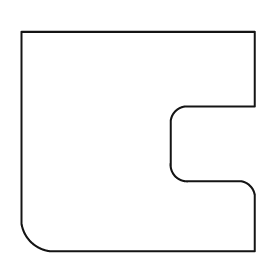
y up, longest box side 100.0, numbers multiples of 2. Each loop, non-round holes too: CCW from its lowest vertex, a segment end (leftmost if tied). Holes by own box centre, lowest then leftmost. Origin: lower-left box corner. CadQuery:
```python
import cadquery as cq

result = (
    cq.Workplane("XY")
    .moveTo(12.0, 0.0)
    .lineTo(100.0, 0.0)
    .lineTo(100.0, 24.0)
    .threePointArc((98.0, 28.0), (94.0, 30.0))
    .lineTo(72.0, 30.0)
    .threePointArc((66.0, 32.0), (64.0, 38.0))
    .lineTo(64.0, 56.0)
    .threePointArc((66.0, 60.0), (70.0, 62.0))
    .lineTo(100.0, 62.0)
    .lineTo(100.0, 94.0)
    .lineTo(0.0, 94.0)
    .lineTo(0.0, 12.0)
    .threePointArc((4.0, 4.0), (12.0, 0.0))
    .close()
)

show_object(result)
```